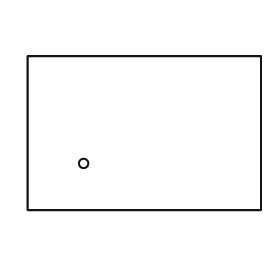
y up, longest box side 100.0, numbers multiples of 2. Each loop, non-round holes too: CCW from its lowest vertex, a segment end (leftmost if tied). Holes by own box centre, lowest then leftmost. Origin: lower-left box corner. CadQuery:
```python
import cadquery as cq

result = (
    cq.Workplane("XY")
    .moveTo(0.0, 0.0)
    .lineTo(100.0, 0.0)
    .lineTo(100.0, 66.0)
    .lineTo(0.0, 66.0)
    .close()
    .moveTo(24.0, 20.0)
    .circle(2.0)
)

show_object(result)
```